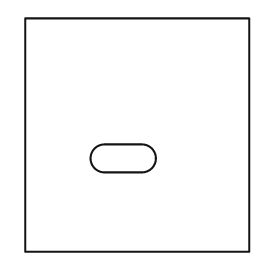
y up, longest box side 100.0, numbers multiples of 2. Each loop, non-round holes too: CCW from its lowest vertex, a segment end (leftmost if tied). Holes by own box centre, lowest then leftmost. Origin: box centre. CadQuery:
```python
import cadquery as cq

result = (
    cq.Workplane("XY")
    .moveTo(-48.0, -50.0)
    .lineTo(48.0, -50.0)
    .lineTo(48.0, 50.0)
    .lineTo(-48.0, 50.0)
    .close()
    .moveTo(-14.0, -16.0)
    .lineTo(2.0, -16.0)
    .threePointArc((8.0, -10.0), (2.0, -4.0))
    .lineTo(-14.0, -4.0)
    .threePointArc((-20.0, -10.0), (-14.0, -16.0))
    .close()
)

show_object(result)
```